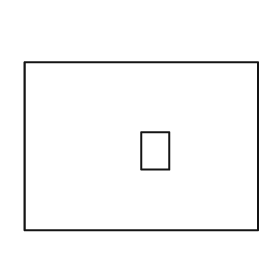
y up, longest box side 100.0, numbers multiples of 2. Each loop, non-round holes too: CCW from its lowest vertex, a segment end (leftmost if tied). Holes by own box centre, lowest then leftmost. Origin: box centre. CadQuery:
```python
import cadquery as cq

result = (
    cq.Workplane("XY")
    .moveTo(-50.0, -36.0)
    .lineTo(50.0, -36.0)
    .lineTo(50.0, 36.0)
    .lineTo(-50.0, 36.0)
    .close()
    .moveTo(0.0, -10.0)
    .lineTo(12.0, -10.0)
    .lineTo(12.0, 6.0)
    .lineTo(0.0, 6.0)
    .close()
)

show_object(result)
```